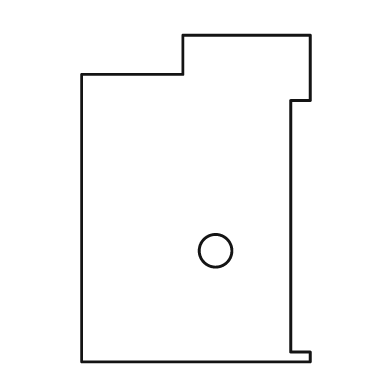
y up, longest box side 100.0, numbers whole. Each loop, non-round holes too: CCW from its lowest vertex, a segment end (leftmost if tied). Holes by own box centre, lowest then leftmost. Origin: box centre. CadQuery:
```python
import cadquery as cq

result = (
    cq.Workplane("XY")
    .moveTo(-35.0, -50.0)
    .lineTo(35.0, -50.0)
    .lineTo(35.0, -47.0)
    .lineTo(29.0, -47.0)
    .lineTo(29.0, 30.0)
    .lineTo(35.0, 30.0)
    .lineTo(35.0, 50.0)
    .lineTo(-4.0, 50.0)
    .lineTo(-4.0, 38.0)
    .lineTo(-35.0, 38.0)
    .close()
    .moveTo(6.0, -16.0)
    .circle(5.0)
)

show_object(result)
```